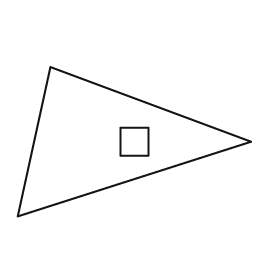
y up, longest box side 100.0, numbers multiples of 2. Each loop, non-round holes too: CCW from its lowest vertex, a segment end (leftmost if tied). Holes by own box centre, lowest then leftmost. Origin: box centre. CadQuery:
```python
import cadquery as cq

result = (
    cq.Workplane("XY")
    .moveTo(-50.0, -32.0)
    .lineTo(50.0, 0.0)
    .lineTo(-36.0, 32.0)
    .close()
    .moveTo(-6.0, -6.0)
    .lineTo(6.0, -6.0)
    .lineTo(6.0, 6.0)
    .lineTo(-6.0, 6.0)
    .close()
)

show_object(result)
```